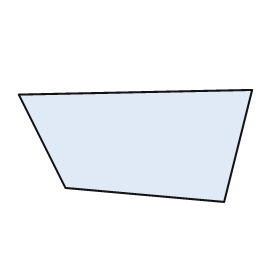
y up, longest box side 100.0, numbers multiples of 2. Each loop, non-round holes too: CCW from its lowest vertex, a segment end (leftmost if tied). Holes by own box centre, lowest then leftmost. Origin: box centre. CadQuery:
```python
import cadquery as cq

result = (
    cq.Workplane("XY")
    .moveTo(38.0, -24.0)
    .lineTo(50.0, 24.0)
    .lineTo(-50.0, 22.0)
    .lineTo(-30.0, -18.0)
    .close()
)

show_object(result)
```